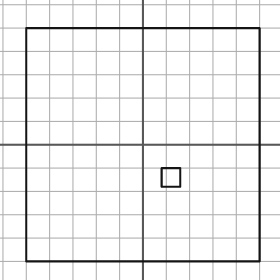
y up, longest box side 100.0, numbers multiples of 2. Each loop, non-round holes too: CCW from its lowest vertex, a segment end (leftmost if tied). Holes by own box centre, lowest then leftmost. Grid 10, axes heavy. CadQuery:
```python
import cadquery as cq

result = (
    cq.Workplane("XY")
    .moveTo(-50.0, -50.0)
    .lineTo(50.0, -50.0)
    .lineTo(50.0, 50.0)
    .lineTo(-50.0, 50.0)
    .close()
    .moveTo(8.0, -18.0)
    .lineTo(16.0, -18.0)
    .lineTo(16.0, -10.0)
    .lineTo(8.0, -10.0)
    .close()
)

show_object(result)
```